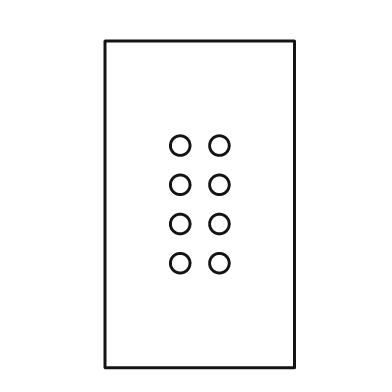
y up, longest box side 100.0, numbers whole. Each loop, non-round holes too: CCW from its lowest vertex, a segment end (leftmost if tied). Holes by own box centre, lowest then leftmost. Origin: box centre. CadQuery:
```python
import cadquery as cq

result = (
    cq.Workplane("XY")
    .moveTo(-29.0, -50.0)
    .lineTo(29.0, -50.0)
    .lineTo(29.0, 50.0)
    .lineTo(-29.0, 50.0)
    .close()
    .moveTo(-6.0, -18.0)
    .circle(3.0)
    .moveTo(6.0, -18.0)
    .circle(3.0)
    .moveTo(-6.0, -6.0)
    .circle(3.0)
    .moveTo(6.0, -6.0)
    .circle(3.0)
    .moveTo(-6.0, 6.0)
    .circle(3.0)
    .moveTo(6.0, 6.0)
    .circle(3.0)
    .moveTo(-6.0, 18.0)
    .circle(3.0)
    .moveTo(6.0, 18.0)
    .circle(3.0)
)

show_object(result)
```